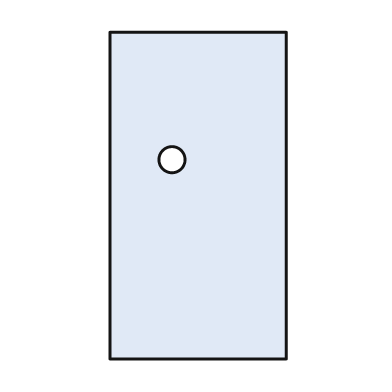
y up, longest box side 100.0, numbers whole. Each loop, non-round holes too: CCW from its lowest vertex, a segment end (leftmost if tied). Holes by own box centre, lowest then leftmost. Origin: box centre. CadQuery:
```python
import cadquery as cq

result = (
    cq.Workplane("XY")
    .moveTo(-27.0, -50.0)
    .lineTo(27.0, -50.0)
    .lineTo(27.0, 50.0)
    .lineTo(-27.0, 50.0)
    .close()
    .moveTo(-8.0, 11.0)
    .circle(4.0)
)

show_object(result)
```